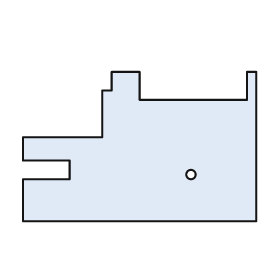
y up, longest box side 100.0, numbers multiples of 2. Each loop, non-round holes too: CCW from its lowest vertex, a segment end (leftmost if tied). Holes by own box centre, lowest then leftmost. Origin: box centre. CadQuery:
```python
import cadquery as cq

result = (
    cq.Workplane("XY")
    .moveTo(-50.0, -32.0)
    .lineTo(50.0, -32.0)
    .lineTo(50.0, 32.0)
    .lineTo(46.0, 32.0)
    .lineTo(46.0, 20.0)
    .lineTo(0.0, 20.0)
    .lineTo(0.0, 32.0)
    .lineTo(-12.0, 32.0)
    .lineTo(-12.0, 24.0)
    .lineTo(-16.0, 24.0)
    .lineTo(-16.0, 4.0)
    .lineTo(-50.0, 4.0)
    .lineTo(-50.0, -6.0)
    .lineTo(-30.0, -6.0)
    .lineTo(-30.0, -14.0)
    .lineTo(-50.0, -14.0)
    .close()
    .moveTo(22.0, -12.0)
    .circle(2.0)
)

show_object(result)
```